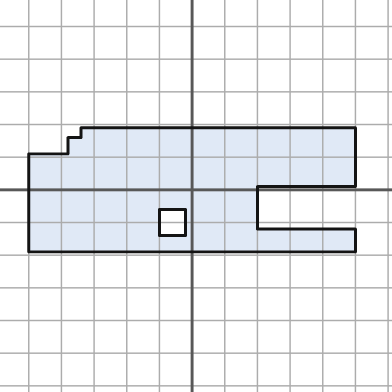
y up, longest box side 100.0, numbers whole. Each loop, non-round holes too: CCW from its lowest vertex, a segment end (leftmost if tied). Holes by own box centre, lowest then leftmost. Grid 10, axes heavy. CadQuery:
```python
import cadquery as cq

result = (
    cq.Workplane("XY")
    .moveTo(-50.0, -19.0)
    .lineTo(50.0, -19.0)
    .lineTo(50.0, -12.0)
    .lineTo(20.0, -12.0)
    .lineTo(20.0, 1.0)
    .lineTo(50.0, 1.0)
    .lineTo(50.0, 19.0)
    .lineTo(-34.0, 19.0)
    .lineTo(-34.0, 16.0)
    .lineTo(-38.0, 16.0)
    .lineTo(-38.0, 11.0)
    .lineTo(-50.0, 11.0)
    .close()
    .moveTo(-10.0, -14.0)
    .lineTo(-2.0, -14.0)
    .lineTo(-2.0, -6.0)
    .lineTo(-10.0, -6.0)
    .close()
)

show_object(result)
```